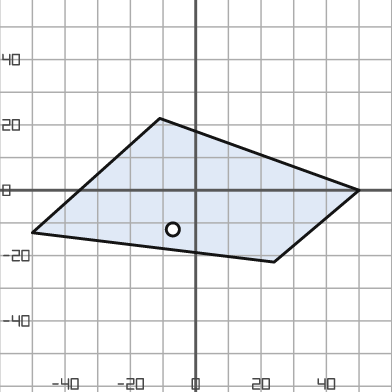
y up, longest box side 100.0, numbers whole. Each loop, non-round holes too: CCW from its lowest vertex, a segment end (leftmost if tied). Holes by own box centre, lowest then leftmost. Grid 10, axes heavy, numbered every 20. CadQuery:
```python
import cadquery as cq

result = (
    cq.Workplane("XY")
    .moveTo(24.0, -22.0)
    .lineTo(50.0, 0.0)
    .lineTo(-11.0, 22.0)
    .lineTo(-50.0, -13.0)
    .close()
    .moveTo(-7.0, -12.0)
    .circle(2.0)
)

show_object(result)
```